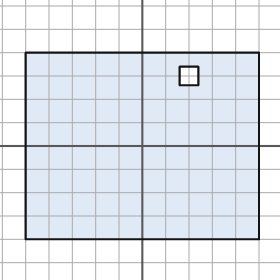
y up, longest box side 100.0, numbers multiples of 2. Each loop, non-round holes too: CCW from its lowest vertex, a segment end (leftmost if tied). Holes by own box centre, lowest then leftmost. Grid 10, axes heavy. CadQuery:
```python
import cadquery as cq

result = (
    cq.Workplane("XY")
    .moveTo(-50.0, -40.0)
    .lineTo(50.0, -40.0)
    .lineTo(50.0, 40.0)
    .lineTo(-50.0, 40.0)
    .close()
    .moveTo(16.0, 26.0)
    .lineTo(24.0, 26.0)
    .lineTo(24.0, 34.0)
    .lineTo(16.0, 34.0)
    .close()
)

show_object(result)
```